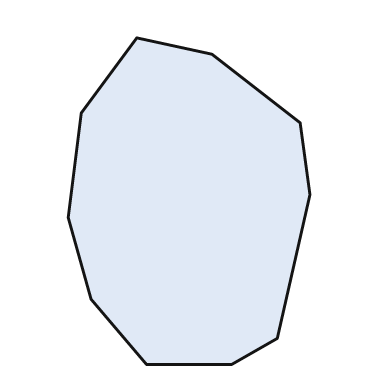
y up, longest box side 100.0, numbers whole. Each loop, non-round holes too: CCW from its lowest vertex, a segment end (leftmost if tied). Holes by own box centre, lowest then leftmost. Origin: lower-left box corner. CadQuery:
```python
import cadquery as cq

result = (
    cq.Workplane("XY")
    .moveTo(24.0, 0.0)
    .lineTo(50.0, 0.0)
    .lineTo(64.0, 8.0)
    .lineTo(74.0, 52.0)
    .lineTo(71.0, 74.0)
    .lineTo(44.0, 95.0)
    .lineTo(21.0, 100.0)
    .lineTo(4.0, 77.0)
    .lineTo(0.0, 45.0)
    .lineTo(7.0, 20.0)
    .close()
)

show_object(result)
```